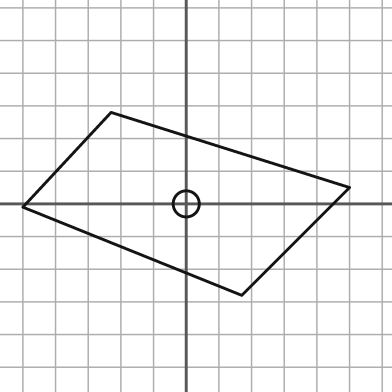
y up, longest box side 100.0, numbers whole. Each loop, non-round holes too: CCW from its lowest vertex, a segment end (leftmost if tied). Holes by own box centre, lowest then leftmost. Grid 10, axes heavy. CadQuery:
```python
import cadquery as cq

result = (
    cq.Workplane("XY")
    .moveTo(17.0, -28.0)
    .lineTo(50.0, 5.0)
    .lineTo(-23.0, 28.0)
    .lineTo(-50.0, -1.0)
    .close()
    .moveTo(0.0, 0.0)
    .circle(4.0)
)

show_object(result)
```